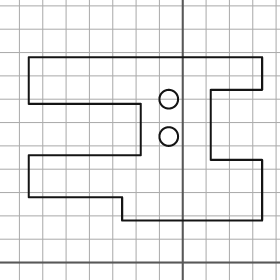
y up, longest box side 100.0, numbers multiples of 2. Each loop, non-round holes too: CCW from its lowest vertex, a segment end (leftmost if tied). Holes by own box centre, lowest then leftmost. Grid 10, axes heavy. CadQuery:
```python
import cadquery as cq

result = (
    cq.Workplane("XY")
    .moveTo(-26.0, 18.0)
    .lineTo(34.0, 18.0)
    .lineTo(34.0, 44.0)
    .lineTo(12.0, 44.0)
    .lineTo(12.0, 74.0)
    .lineTo(34.0, 74.0)
    .lineTo(34.0, 88.0)
    .lineTo(-66.0, 88.0)
    .lineTo(-66.0, 68.0)
    .lineTo(-18.0, 68.0)
    .lineTo(-18.0, 46.0)
    .lineTo(-66.0, 46.0)
    .lineTo(-66.0, 28.0)
    .lineTo(-26.0, 28.0)
    .close()
    .moveTo(-6.0, 54.0)
    .circle(4.0)
    .moveTo(-6.0, 70.0)
    .circle(4.0)
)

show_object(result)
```